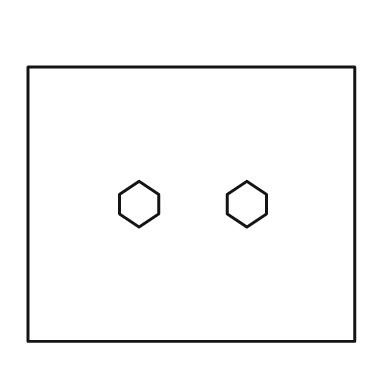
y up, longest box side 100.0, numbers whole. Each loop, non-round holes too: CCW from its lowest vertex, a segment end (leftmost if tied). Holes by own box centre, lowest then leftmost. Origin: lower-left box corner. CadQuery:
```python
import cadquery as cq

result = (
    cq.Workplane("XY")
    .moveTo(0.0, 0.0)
    .lineTo(100.0, 0.0)
    .lineTo(100.0, 84.0)
    .lineTo(0.0, 84.0)
    .close()
    .moveTo(34.0, 35.0)
    .lineTo(40.0, 39.0)
    .lineTo(40.0, 45.0)
    .lineTo(34.0, 49.0)
    .lineTo(28.0, 45.0)
    .lineTo(28.0, 39.0)
    .close()
    .moveTo(67.0, 35.0)
    .lineTo(73.0, 39.0)
    .lineTo(73.0, 45.0)
    .lineTo(67.0, 49.0)
    .lineTo(61.0, 45.0)
    .lineTo(61.0, 39.0)
    .close()
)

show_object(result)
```